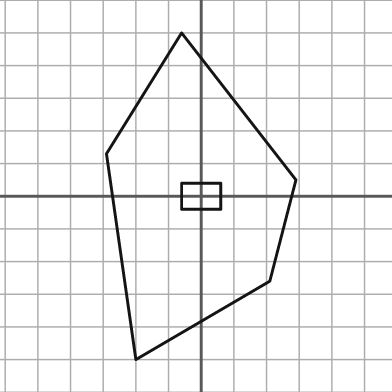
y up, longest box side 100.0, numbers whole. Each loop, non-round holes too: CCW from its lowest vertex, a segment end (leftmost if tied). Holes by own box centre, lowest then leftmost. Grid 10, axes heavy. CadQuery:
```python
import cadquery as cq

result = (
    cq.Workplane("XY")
    .moveTo(-20.0, -50.0)
    .lineTo(21.0, -26.0)
    .lineTo(29.0, 5.0)
    .lineTo(-6.0, 50.0)
    .lineTo(-29.0, 13.0)
    .close()
    .moveTo(-6.0, -4.0)
    .lineTo(6.0, -4.0)
    .lineTo(6.0, 4.0)
    .lineTo(-6.0, 4.0)
    .close()
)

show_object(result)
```